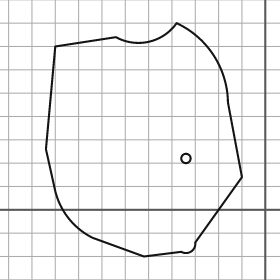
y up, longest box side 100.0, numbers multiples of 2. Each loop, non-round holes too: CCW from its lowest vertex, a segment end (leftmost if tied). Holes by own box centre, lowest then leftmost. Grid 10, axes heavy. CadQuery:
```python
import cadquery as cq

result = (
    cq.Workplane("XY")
    .moveTo(-52.0, -20.0)
    .lineTo(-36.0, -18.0)
    .threePointArc((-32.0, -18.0), (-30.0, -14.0))
    .lineTo(-10.0, 14.0)
    .lineTo(-16.0, 46.0)
    .threePointArc((-22.0, 66.0), (-38.0, 80.0))
    .threePointArc((-50.0, 72.0), (-64.0, 74.0))
    .lineTo(-90.0, 70.0)
    .lineTo(-94.0, 26.0)
    .lineTo(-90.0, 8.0)
    .threePointArc((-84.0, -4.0), (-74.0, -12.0))
    .close()
    .moveTo(-34.0, 22.0)
    .circle(2.0)
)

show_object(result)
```